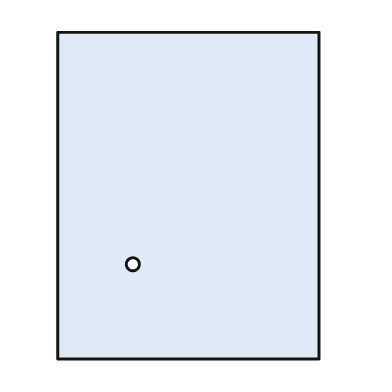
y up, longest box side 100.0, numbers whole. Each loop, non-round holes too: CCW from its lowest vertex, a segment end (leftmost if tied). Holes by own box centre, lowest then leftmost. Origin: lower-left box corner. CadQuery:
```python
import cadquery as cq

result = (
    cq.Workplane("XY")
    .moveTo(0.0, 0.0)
    .lineTo(80.0, 0.0)
    .lineTo(80.0, 100.0)
    .lineTo(0.0, 100.0)
    .close()
    .moveTo(23.0, 29.0)
    .circle(2.0)
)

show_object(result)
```